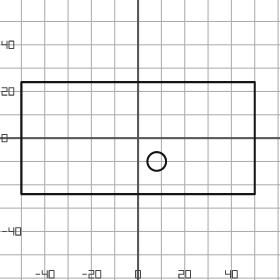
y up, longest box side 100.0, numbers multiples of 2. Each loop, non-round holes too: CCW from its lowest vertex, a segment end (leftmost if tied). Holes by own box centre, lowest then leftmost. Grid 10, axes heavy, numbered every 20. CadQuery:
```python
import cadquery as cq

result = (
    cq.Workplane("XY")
    .moveTo(-50.0, -24.0)
    .lineTo(50.0, -24.0)
    .lineTo(50.0, 24.0)
    .lineTo(-50.0, 24.0)
    .close()
    .moveTo(8.0, -10.0)
    .circle(4.0)
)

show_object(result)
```